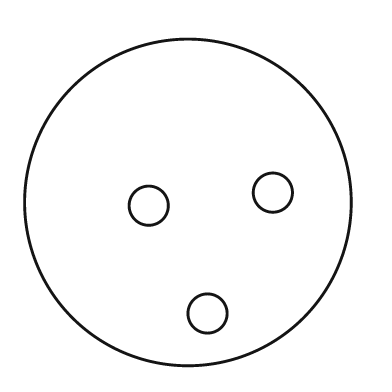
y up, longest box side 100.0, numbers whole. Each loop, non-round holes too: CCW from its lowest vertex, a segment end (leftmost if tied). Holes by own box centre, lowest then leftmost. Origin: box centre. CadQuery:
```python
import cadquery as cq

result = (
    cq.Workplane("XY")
    .moveTo(0.0, 0.0)
    .circle(50.0)
    .moveTo(6.0, -34.0)
    .circle(6.0)
    .moveTo(-12.0, -1.0)
    .circle(6.0)
    .moveTo(26.0, 3.0)
    .circle(6.0)
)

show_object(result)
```